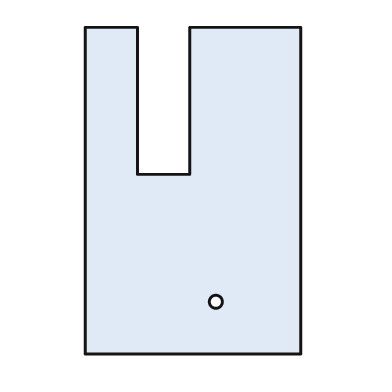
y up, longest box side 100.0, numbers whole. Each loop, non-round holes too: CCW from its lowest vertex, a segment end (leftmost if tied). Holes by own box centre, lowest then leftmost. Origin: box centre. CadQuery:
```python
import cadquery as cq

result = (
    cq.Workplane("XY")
    .moveTo(-33.0, -50.0)
    .lineTo(33.0, -50.0)
    .lineTo(33.0, 50.0)
    .lineTo(-1.0, 50.0)
    .lineTo(-1.0, 5.0)
    .lineTo(-17.0, 5.0)
    .lineTo(-17.0, 50.0)
    .lineTo(-33.0, 50.0)
    .close()
    .moveTo(7.0, -34.0)
    .circle(2.0)
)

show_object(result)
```